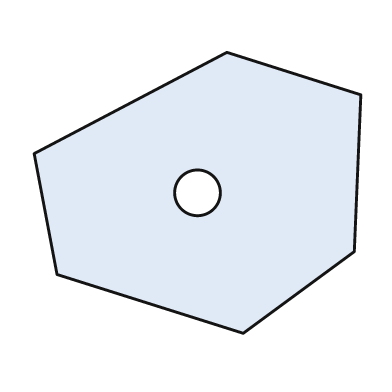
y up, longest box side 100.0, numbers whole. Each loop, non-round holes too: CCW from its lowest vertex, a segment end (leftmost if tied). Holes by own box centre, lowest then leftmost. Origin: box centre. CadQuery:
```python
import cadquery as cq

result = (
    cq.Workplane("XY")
    .moveTo(14.0, -43.0)
    .lineTo(48.0, -18.0)
    .lineTo(50.0, 30.0)
    .lineTo(9.0, 43.0)
    .lineTo(-50.0, 12.0)
    .lineTo(-43.0, -25.0)
    .close()
    .moveTo(0.0, 0.0)
    .circle(7.0)
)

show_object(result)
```